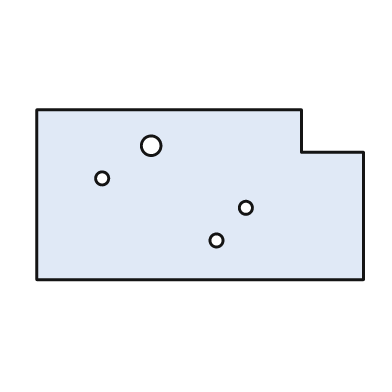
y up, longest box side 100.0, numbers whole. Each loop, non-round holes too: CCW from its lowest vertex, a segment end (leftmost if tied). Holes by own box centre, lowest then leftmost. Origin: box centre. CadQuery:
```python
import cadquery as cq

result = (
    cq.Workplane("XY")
    .moveTo(-50.0, -26.0)
    .lineTo(50.0, -26.0)
    .lineTo(50.0, 13.0)
    .lineTo(31.0, 13.0)
    .lineTo(31.0, 26.0)
    .lineTo(-50.0, 26.0)
    .close()
    .moveTo(5.0, -14.0)
    .circle(2.0)
    .moveTo(14.0, -4.0)
    .circle(2.0)
    .moveTo(-30.0, 5.0)
    .circle(2.0)
    .moveTo(-15.0, 15.0)
    .circle(3.0)
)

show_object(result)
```